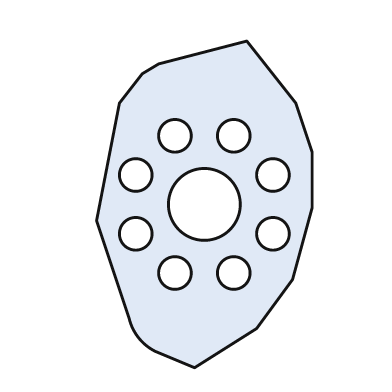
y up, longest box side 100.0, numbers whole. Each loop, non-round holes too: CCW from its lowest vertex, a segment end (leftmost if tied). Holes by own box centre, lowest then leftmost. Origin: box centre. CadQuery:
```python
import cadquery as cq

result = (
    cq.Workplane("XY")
    .moveTo(-3.0, -50.0)
    .lineTo(16.0, -38.0)
    .lineTo(27.0, -23.0)
    .lineTo(33.0, -1.0)
    .lineTo(33.0, 16.0)
    .lineTo(28.0, 31.0)
    .lineTo(13.0, 50.0)
    .lineTo(-14.0, 43.0)
    .lineTo(-19.0, 40.0)
    .lineTo(-26.0, 31.0)
    .lineTo(-33.0, -5.0)
    .lineTo(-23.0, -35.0)
    .threePointArc((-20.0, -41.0), (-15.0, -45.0))
    .close()
    .moveTo(-9.0, -21.0)
    .circle(5.0)
    .moveTo(9.0, -21.0)
    .circle(5.0)
    .moveTo(-21.0, -9.0)
    .circle(5.0)
    .moveTo(21.0, -9.0)
    .circle(5.0)
    .moveTo(0.0, 0.0)
    .circle(11.0)
    .moveTo(-21.0, 9.0)
    .circle(5.0)
    .moveTo(21.0, 9.0)
    .circle(5.0)
    .moveTo(-9.0, 21.0)
    .circle(5.0)
    .moveTo(9.0, 21.0)
    .circle(5.0)
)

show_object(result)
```